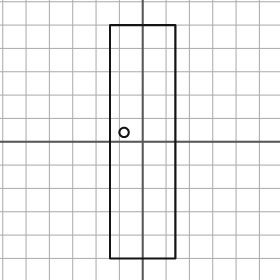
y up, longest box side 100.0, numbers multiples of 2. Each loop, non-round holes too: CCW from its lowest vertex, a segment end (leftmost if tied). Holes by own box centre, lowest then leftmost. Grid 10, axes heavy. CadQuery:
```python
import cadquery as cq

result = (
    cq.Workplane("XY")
    .moveTo(-14.0, -50.0)
    .lineTo(14.0, -50.0)
    .lineTo(14.0, 50.0)
    .lineTo(-14.0, 50.0)
    .close()
    .moveTo(-8.0, 4.0)
    .circle(2.0)
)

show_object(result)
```